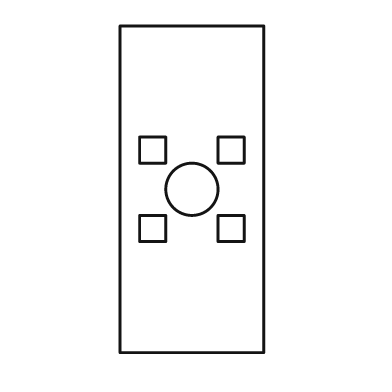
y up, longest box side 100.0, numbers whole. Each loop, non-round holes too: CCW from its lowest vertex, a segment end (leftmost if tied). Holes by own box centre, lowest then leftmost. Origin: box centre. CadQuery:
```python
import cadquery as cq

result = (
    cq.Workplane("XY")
    .moveTo(-22.0, -50.0)
    .lineTo(22.0, -50.0)
    .lineTo(22.0, 50.0)
    .lineTo(-22.0, 50.0)
    .close()
    .moveTo(-16.0, -16.0)
    .lineTo(-8.0, -16.0)
    .lineTo(-8.0, -8.0)
    .lineTo(-16.0, -8.0)
    .close()
    .moveTo(8.0, -16.0)
    .lineTo(16.0, -16.0)
    .lineTo(16.0, -8.0)
    .lineTo(8.0, -8.0)
    .close()
    .moveTo(0.0, 0.0)
    .circle(8.0)
    .moveTo(-16.0, 8.0)
    .lineTo(-8.0, 8.0)
    .lineTo(-8.0, 16.0)
    .lineTo(-16.0, 16.0)
    .close()
    .moveTo(8.0, 8.0)
    .lineTo(16.0, 8.0)
    .lineTo(16.0, 16.0)
    .lineTo(8.0, 16.0)
    .close()
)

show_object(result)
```